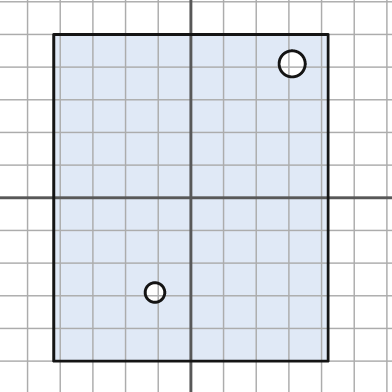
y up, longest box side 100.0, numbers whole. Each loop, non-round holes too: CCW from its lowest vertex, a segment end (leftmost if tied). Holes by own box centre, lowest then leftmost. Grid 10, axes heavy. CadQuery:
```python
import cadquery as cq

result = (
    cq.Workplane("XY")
    .moveTo(-42.0, -50.0)
    .lineTo(42.0, -50.0)
    .lineTo(42.0, 50.0)
    .lineTo(-42.0, 50.0)
    .close()
    .moveTo(-11.0, -29.0)
    .circle(3.0)
    .moveTo(31.0, 41.0)
    .circle(4.0)
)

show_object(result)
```